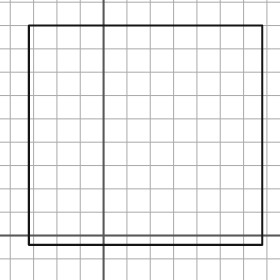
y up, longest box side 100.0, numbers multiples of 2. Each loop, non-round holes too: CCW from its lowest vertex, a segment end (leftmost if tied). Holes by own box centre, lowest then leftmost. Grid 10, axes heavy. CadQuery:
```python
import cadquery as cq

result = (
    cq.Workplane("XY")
    .moveTo(-32.0, -4.0)
    .lineTo(68.0, -4.0)
    .lineTo(68.0, 90.0)
    .lineTo(-32.0, 90.0)
    .close()
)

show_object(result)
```